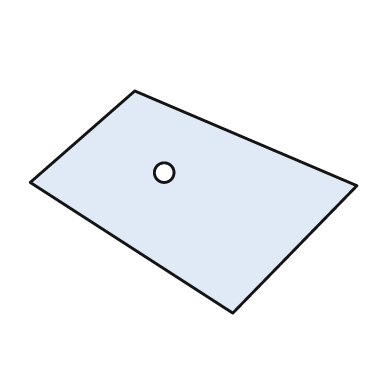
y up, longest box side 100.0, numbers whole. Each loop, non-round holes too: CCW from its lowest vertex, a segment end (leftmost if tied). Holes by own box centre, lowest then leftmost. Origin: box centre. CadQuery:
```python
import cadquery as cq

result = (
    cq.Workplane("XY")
    .moveTo(12.0, -34.0)
    .lineTo(50.0, 5.0)
    .lineTo(-18.0, 34.0)
    .lineTo(-50.0, 6.0)
    .close()
    .moveTo(-9.0, 9.0)
    .circle(3.0)
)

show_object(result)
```